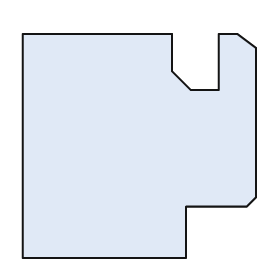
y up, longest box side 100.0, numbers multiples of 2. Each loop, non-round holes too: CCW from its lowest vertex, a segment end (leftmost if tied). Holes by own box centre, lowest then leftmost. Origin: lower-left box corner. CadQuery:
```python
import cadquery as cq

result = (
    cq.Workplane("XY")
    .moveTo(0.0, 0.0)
    .lineTo(70.0, 0.0)
    .lineTo(70.0, 22.0)
    .lineTo(96.0, 22.0)
    .lineTo(100.0, 26.0)
    .lineTo(100.0, 90.0)
    .lineTo(92.0, 96.0)
    .lineTo(84.0, 96.0)
    .lineTo(84.0, 72.0)
    .lineTo(72.0, 72.0)
    .lineTo(64.0, 80.0)
    .lineTo(64.0, 96.0)
    .lineTo(0.0, 96.0)
    .close()
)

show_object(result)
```